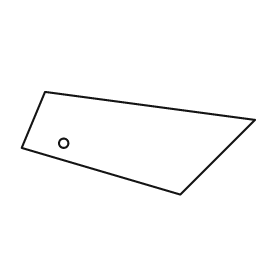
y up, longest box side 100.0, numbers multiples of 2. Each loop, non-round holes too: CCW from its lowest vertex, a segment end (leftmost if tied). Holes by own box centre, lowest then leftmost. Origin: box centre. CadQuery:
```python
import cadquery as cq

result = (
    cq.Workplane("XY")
    .moveTo(18.0, -22.0)
    .lineTo(50.0, 10.0)
    .lineTo(-40.0, 22.0)
    .lineTo(-50.0, -2.0)
    .close()
    .moveTo(-32.0, 0.0)
    .circle(2.0)
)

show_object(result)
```